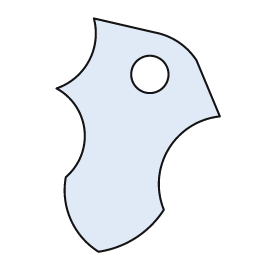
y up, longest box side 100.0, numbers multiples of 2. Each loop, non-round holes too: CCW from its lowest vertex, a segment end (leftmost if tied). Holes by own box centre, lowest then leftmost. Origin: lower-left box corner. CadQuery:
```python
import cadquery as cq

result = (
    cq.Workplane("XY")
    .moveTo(18.0, 0.0)
    .threePointArc((34.0, 6.0), (46.0, 18.0))
    .threePointArc((48.0, 44.0), (70.0, 58.0))
    .lineTo(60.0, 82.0)
    .threePointArc((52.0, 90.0), (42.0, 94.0))
    .lineTo(16.0, 100.0)
    .threePointArc((14.0, 82.0), (0.0, 70.0))
    .threePointArc((12.0, 52.0), (4.0, 32.0))
    .threePointArc((6.0, 14.0), (18.0, 0.0))
    .close()
    .moveTo(40.0, 76.0)
    .circle(8.0)
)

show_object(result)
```